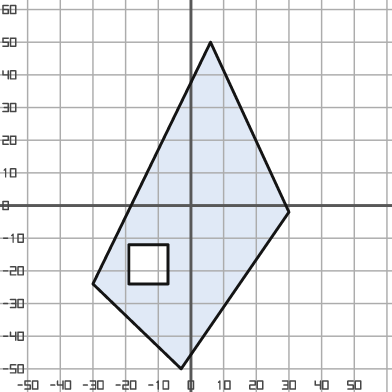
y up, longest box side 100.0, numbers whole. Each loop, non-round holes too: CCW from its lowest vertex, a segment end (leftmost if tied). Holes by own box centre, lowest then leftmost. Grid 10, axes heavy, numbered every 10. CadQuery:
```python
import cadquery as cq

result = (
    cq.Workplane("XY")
    .moveTo(-3.0, -50.0)
    .lineTo(30.0, -2.0)
    .lineTo(6.0, 50.0)
    .lineTo(-30.0, -24.0)
    .close()
    .moveTo(-19.0, -24.0)
    .lineTo(-7.0, -24.0)
    .lineTo(-7.0, -12.0)
    .lineTo(-19.0, -12.0)
    .close()
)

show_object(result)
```